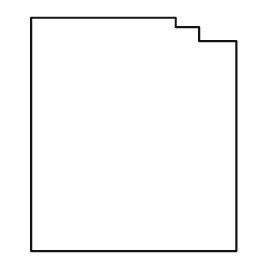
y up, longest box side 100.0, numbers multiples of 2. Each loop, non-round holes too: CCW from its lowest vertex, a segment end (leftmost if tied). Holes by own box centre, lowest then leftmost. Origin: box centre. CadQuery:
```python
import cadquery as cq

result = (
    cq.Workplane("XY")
    .moveTo(-44.0, -50.0)
    .lineTo(44.0, -50.0)
    .lineTo(44.0, 40.0)
    .lineTo(28.0, 40.0)
    .lineTo(28.0, 46.0)
    .lineTo(18.0, 46.0)
    .lineTo(18.0, 50.0)
    .lineTo(-44.0, 50.0)
    .close()
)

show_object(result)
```